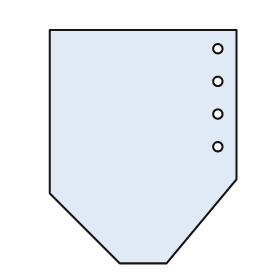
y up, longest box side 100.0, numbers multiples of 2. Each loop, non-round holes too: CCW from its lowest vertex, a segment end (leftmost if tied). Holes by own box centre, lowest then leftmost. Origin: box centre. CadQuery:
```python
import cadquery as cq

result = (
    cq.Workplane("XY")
    .moveTo(-10.0, -50.0)
    .lineTo(10.0, -50.0)
    .lineTo(40.0, -14.0)
    .lineTo(40.0, 50.0)
    .lineTo(-40.0, 50.0)
    .lineTo(-40.0, -20.0)
    .close()
    .moveTo(32.0, 0.0)
    .circle(2.0)
    .moveTo(32.0, 14.0)
    .circle(2.0)
    .moveTo(32.0, 28.0)
    .circle(2.0)
    .moveTo(32.0, 42.0)
    .circle(2.0)
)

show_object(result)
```